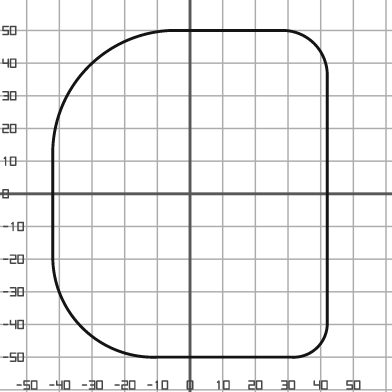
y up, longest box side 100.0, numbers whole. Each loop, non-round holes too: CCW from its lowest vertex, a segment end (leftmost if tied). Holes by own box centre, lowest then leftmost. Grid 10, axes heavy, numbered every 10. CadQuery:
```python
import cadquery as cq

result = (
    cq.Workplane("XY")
    .moveTo(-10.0, -50.0)
    .lineTo(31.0, -50.0)
    .threePointArc((39.0, -47.0), (42.0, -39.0))
    .lineTo(42.0, 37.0)
    .threePointArc((38.0, 46.0), (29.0, 50.0))
    .lineTo(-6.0, 50.0)
    .threePointArc((-31.0, 39.0), (-42.0, 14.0))
    .lineTo(-42.0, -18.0)
    .threePointArc((-33.0, -41.0), (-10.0, -50.0))
    .close()
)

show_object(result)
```